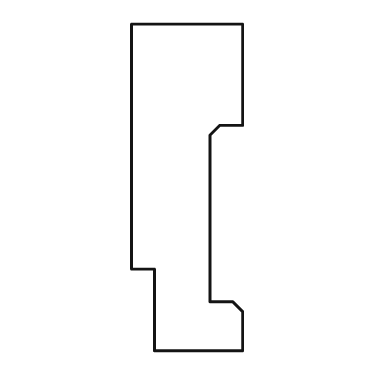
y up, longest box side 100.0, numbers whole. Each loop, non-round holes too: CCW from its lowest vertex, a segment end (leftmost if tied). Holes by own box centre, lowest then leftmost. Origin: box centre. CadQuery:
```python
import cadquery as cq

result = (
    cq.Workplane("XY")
    .moveTo(-10.0, -50.0)
    .lineTo(17.0, -50.0)
    .lineTo(17.0, -38.0)
    .lineTo(14.0, -35.0)
    .lineTo(7.0, -35.0)
    .lineTo(7.0, 16.0)
    .lineTo(10.0, 19.0)
    .lineTo(17.0, 19.0)
    .lineTo(17.0, 50.0)
    .lineTo(-17.0, 50.0)
    .lineTo(-17.0, -25.0)
    .lineTo(-10.0, -25.0)
    .close()
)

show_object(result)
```